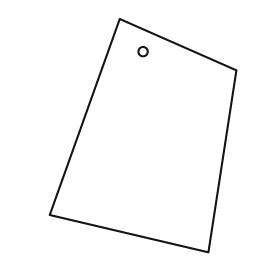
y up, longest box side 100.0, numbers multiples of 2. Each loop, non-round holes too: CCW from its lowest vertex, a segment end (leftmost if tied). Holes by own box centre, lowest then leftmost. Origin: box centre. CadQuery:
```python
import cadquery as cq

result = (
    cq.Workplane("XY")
    .moveTo(28.0, -50.0)
    .lineTo(40.0, 28.0)
    .lineTo(-10.0, 50.0)
    .lineTo(-40.0, -34.0)
    .close()
    .moveTo(0.0, 36.0)
    .circle(2.0)
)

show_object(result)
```